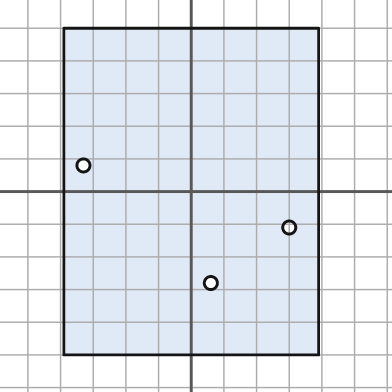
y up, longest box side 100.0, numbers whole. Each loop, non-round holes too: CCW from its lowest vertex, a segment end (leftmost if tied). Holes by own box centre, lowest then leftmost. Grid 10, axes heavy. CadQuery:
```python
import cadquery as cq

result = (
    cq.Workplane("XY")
    .moveTo(-39.0, -50.0)
    .lineTo(39.0, -50.0)
    .lineTo(39.0, 50.0)
    .lineTo(-39.0, 50.0)
    .close()
    .moveTo(6.0, -28.0)
    .circle(2.0)
    .moveTo(30.0, -11.0)
    .circle(2.0)
    .moveTo(-33.0, 8.0)
    .circle(2.0)
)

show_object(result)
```